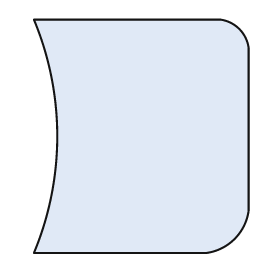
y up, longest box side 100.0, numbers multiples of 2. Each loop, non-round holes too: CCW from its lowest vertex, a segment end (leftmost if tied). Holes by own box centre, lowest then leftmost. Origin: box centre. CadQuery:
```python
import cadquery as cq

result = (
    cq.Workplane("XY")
    .moveTo(-46.0, -50.0)
    .lineTo(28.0, -50.0)
    .threePointArc((40.0, -44.0), (46.0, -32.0))
    .lineTo(46.0, 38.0)
    .threePointArc((42.0, 46.0), (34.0, 50.0))
    .lineTo(-46.0, 50.0)
    .threePointArc((-36.0, 0.0), (-46.0, -50.0))
    .close()
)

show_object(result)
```